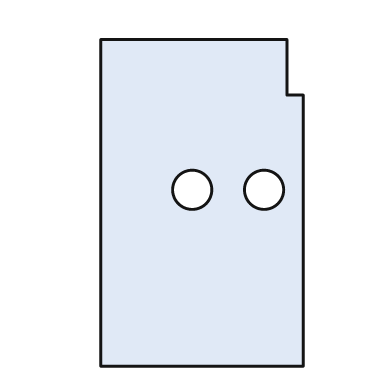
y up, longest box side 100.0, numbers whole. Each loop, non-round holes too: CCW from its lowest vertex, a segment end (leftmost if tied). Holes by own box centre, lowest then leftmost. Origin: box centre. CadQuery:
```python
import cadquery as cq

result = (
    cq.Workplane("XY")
    .moveTo(-31.0, -50.0)
    .lineTo(31.0, -50.0)
    .lineTo(31.0, 33.0)
    .lineTo(26.0, 33.0)
    .lineTo(26.0, 50.0)
    .lineTo(-31.0, 50.0)
    .close()
    .moveTo(-3.0, 4.0)
    .circle(6.0)
    .moveTo(19.0, 4.0)
    .circle(6.0)
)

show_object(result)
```